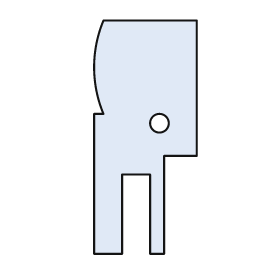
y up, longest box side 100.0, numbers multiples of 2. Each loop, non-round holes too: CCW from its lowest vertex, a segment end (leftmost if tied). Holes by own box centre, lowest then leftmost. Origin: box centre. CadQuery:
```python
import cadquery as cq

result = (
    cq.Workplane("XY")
    .moveTo(-22.0, -50.0)
    .lineTo(-10.0, -50.0)
    .lineTo(-10.0, -16.0)
    .lineTo(2.0, -16.0)
    .lineTo(2.0, -50.0)
    .lineTo(8.0, -50.0)
    .lineTo(8.0, -8.0)
    .lineTo(22.0, -8.0)
    .lineTo(22.0, 50.0)
    .lineTo(-18.0, 50.0)
    .threePointArc((-22.0, 30.0), (-18.0, 10.0))
    .lineTo(-22.0, 10.0)
    .close()
    .moveTo(6.0, 6.0)
    .circle(4.0)
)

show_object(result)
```